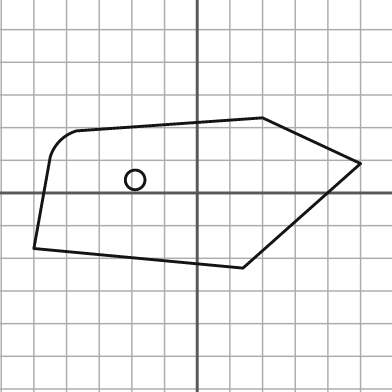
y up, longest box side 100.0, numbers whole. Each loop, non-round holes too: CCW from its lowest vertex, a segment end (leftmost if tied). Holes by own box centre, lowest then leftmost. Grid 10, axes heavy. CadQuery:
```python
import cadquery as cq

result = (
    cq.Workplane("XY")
    .moveTo(14.0, -23.0)
    .lineTo(50.0, 9.0)
    .lineTo(20.0, 23.0)
    .lineTo(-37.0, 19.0)
    .threePointArc((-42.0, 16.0), (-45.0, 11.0))
    .lineTo(-50.0, -17.0)
    .close()
    .moveTo(-19.0, 4.0)
    .circle(3.0)
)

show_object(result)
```